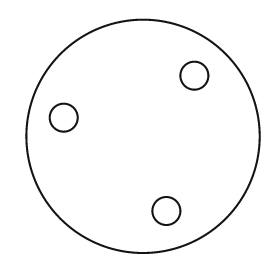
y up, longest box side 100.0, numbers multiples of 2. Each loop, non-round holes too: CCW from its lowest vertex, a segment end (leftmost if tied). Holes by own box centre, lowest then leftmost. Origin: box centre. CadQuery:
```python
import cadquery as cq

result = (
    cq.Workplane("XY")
    .moveTo(0.0, 0.0)
    .circle(50.0)
    .moveTo(10.0, -32.0)
    .circle(6.0)
    .moveTo(-34.0, 8.0)
    .circle(6.0)
    .moveTo(22.0, 26.0)
    .circle(6.0)
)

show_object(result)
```